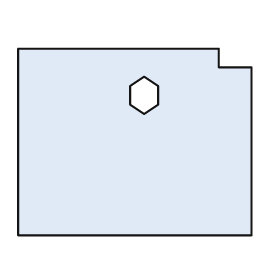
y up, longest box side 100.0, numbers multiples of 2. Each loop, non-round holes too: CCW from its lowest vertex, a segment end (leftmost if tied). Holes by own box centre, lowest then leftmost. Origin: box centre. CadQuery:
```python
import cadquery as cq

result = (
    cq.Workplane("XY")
    .moveTo(-50.0, -40.0)
    .lineTo(50.0, -40.0)
    .lineTo(50.0, 32.0)
    .lineTo(36.0, 32.0)
    .lineTo(36.0, 40.0)
    .lineTo(-50.0, 40.0)
    .close()
    .moveTo(4.0, 12.0)
    .lineTo(10.0, 16.0)
    .lineTo(10.0, 24.0)
    .lineTo(4.0, 28.0)
    .lineTo(-2.0, 24.0)
    .lineTo(-2.0, 16.0)
    .close()
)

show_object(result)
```